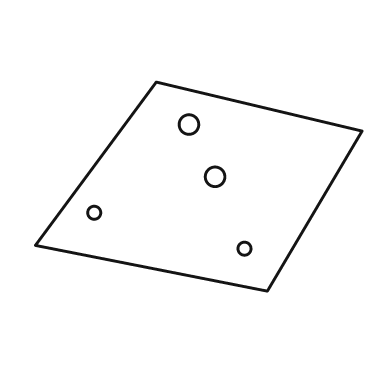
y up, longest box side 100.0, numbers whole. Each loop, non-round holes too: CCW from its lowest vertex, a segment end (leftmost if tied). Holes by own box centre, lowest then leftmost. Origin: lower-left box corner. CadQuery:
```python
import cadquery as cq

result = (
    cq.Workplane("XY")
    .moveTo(71.0, 0.0)
    .lineTo(100.0, 49.0)
    .lineTo(37.0, 64.0)
    .lineTo(0.0, 14.0)
    .close()
    .moveTo(64.0, 13.0)
    .circle(2.0)
    .moveTo(18.0, 24.0)
    .circle(2.0)
    .moveTo(55.0, 35.0)
    .circle(3.0)
    .moveTo(47.0, 51.0)
    .circle(3.0)
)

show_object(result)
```